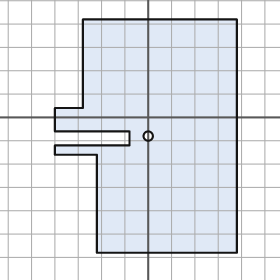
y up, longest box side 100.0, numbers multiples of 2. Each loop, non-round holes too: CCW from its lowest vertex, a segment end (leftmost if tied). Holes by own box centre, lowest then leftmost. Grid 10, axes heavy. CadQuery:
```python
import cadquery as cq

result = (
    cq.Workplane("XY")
    .moveTo(-22.0, -58.0)
    .lineTo(38.0, -58.0)
    .lineTo(38.0, 42.0)
    .lineTo(-28.0, 42.0)
    .lineTo(-28.0, 4.0)
    .lineTo(-40.0, 4.0)
    .lineTo(-40.0, -6.0)
    .lineTo(-8.0, -6.0)
    .lineTo(-8.0, -12.0)
    .lineTo(-40.0, -12.0)
    .lineTo(-40.0, -16.0)
    .lineTo(-22.0, -16.0)
    .close()
    .moveTo(0.0, -8.0)
    .circle(2.0)
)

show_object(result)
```